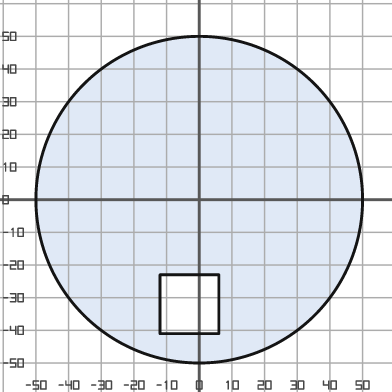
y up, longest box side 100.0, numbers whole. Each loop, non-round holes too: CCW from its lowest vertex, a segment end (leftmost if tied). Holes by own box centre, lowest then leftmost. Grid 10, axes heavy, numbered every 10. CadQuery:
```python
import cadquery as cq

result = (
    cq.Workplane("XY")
    .moveTo(0.0, 0.0)
    .circle(50.0)
    .moveTo(-12.0, -41.0)
    .lineTo(6.0, -41.0)
    .lineTo(6.0, -23.0)
    .lineTo(-12.0, -23.0)
    .close()
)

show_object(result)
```